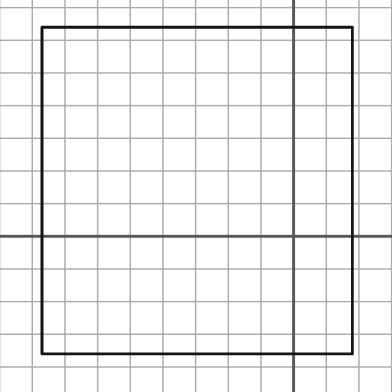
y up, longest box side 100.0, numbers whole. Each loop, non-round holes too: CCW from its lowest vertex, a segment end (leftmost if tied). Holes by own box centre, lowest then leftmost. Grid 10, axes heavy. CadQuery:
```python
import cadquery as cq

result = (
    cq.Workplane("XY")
    .moveTo(-77.0, -36.0)
    .lineTo(18.0, -36.0)
    .lineTo(18.0, 64.0)
    .lineTo(-77.0, 64.0)
    .close()
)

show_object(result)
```